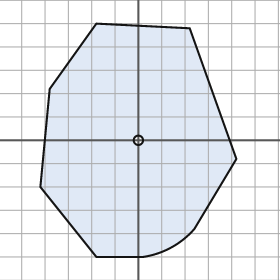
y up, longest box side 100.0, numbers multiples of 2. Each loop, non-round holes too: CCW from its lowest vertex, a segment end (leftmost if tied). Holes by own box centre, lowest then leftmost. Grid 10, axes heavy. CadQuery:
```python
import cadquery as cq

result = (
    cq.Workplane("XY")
    .moveTo(-18.0, -50.0)
    .lineTo(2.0, -50.0)
    .threePointArc((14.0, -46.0), (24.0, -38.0))
    .lineTo(42.0, -8.0)
    .lineTo(22.0, 48.0)
    .lineTo(-18.0, 50.0)
    .lineTo(-38.0, 22.0)
    .lineTo(-42.0, -20.0)
    .close()
    .moveTo(0.0, 0.0)
    .circle(2.0)
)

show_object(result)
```